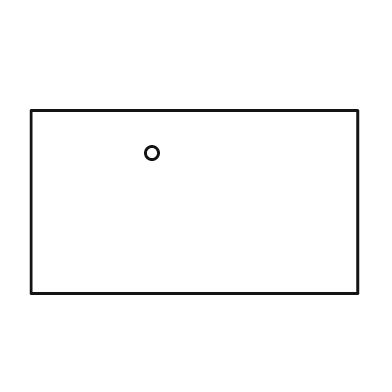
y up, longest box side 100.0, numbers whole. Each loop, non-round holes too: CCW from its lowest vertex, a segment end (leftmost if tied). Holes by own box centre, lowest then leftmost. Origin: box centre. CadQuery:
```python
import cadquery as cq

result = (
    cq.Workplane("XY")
    .moveTo(-50.0, -28.0)
    .lineTo(50.0, -28.0)
    .lineTo(50.0, 28.0)
    .lineTo(-50.0, 28.0)
    .close()
    .moveTo(-13.0, 15.0)
    .circle(2.0)
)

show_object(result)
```